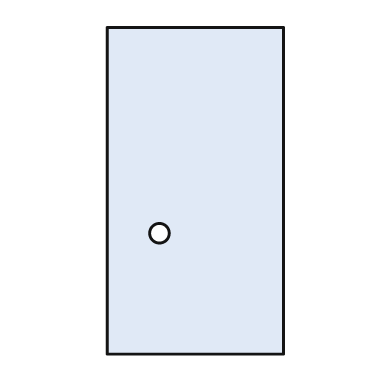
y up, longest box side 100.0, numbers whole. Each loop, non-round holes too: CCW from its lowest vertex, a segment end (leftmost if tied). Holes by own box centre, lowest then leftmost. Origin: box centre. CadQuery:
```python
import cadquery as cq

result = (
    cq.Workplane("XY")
    .moveTo(-27.0, -50.0)
    .lineTo(27.0, -50.0)
    .lineTo(27.0, 50.0)
    .lineTo(-27.0, 50.0)
    .close()
    .moveTo(-11.0, -13.0)
    .circle(3.0)
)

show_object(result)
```